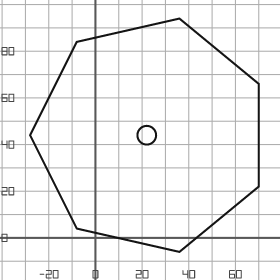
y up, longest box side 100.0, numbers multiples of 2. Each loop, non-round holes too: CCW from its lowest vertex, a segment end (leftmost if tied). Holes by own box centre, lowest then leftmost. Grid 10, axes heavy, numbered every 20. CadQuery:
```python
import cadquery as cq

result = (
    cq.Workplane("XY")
    .moveTo(36.0, -6.0)
    .lineTo(70.0, 22.0)
    .lineTo(70.0, 66.0)
    .lineTo(36.0, 94.0)
    .lineTo(-8.0, 84.0)
    .lineTo(-28.0, 44.0)
    .lineTo(-8.0, 4.0)
    .close()
    .moveTo(22.0, 44.0)
    .circle(4.0)
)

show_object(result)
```